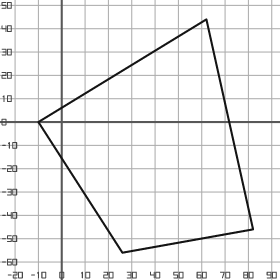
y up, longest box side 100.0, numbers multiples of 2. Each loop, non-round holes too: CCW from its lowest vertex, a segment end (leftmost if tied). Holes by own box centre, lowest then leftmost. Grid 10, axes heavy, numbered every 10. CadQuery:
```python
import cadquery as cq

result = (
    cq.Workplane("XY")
    .moveTo(26.0, -56.0)
    .lineTo(82.0, -46.0)
    .lineTo(62.0, 44.0)
    .lineTo(-10.0, 0.0)
    .close()
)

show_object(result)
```